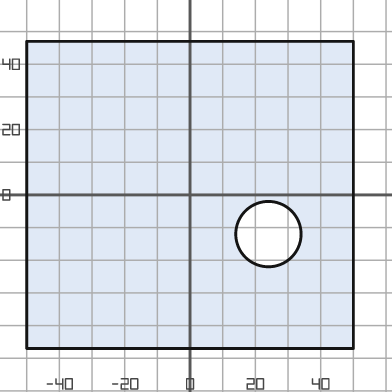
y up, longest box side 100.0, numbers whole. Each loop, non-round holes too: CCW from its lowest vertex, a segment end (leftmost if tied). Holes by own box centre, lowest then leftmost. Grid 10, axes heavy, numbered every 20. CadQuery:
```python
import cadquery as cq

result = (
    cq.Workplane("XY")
    .moveTo(-50.0, -47.0)
    .lineTo(50.0, -47.0)
    .lineTo(50.0, 47.0)
    .lineTo(-50.0, 47.0)
    .close()
    .moveTo(24.0, -12.0)
    .circle(10.0)
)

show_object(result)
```